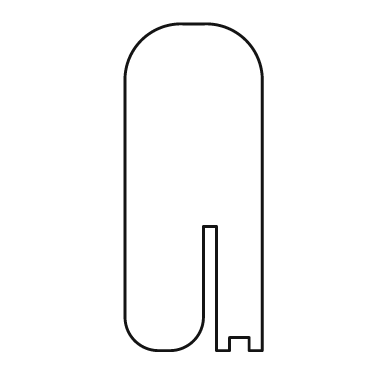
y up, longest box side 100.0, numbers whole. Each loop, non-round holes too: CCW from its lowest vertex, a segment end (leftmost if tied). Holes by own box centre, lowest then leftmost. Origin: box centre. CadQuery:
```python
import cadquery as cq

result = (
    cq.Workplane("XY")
    .moveTo(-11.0, -50.0)
    .lineTo(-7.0, -50.0)
    .threePointArc((0.0, -47.0), (3.0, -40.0))
    .lineTo(3.0, -12.0)
    .lineTo(7.0, -12.0)
    .lineTo(7.0, -50.0)
    .lineTo(11.0, -50.0)
    .lineTo(11.0, -46.0)
    .lineTo(17.0, -46.0)
    .lineTo(17.0, -50.0)
    .lineTo(21.0, -50.0)
    .lineTo(21.0, 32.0)
    .threePointArc((16.0, 45.0), (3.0, 50.0))
    .lineTo(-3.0, 50.0)
    .threePointArc((-16.0, 45.0), (-21.0, 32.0))
    .lineTo(-21.0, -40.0)
    .threePointArc((-18.0, -47.0), (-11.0, -50.0))
    .close()
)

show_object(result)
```